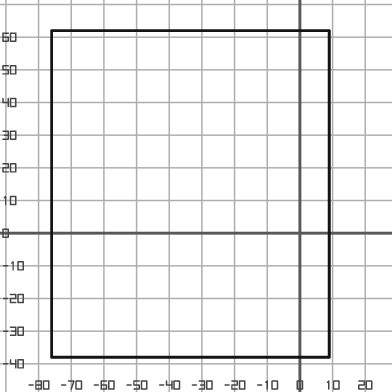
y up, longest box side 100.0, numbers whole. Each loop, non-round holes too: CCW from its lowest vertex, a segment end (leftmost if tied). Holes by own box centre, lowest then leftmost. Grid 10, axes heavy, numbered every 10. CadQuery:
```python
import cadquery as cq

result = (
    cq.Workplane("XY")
    .moveTo(-76.0, -38.0)
    .lineTo(9.0, -38.0)
    .lineTo(9.0, 62.0)
    .lineTo(-76.0, 62.0)
    .close()
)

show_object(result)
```